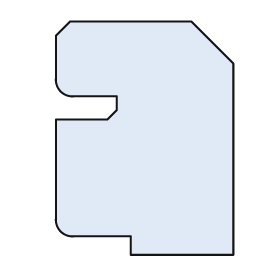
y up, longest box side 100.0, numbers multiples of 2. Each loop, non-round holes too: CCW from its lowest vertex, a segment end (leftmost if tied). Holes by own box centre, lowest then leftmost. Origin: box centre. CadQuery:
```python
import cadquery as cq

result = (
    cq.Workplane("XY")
    .moveTo(-6.0, -50.0)
    .lineTo(38.0, -50.0)
    .lineTo(38.0, 32.0)
    .lineTo(20.0, 50.0)
    .lineTo(-32.0, 50.0)
    .lineTo(-38.0, 44.0)
    .lineTo(-38.0, 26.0)
    .threePointArc((-36.0, 20.0), (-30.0, 18.0))
    .lineTo(-12.0, 18.0)
    .lineTo(-12.0, 12.0)
    .lineTo(-16.0, 8.0)
    .lineTo(-38.0, 8.0)
    .lineTo(-38.0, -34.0)
    .threePointArc((-36.0, -40.0), (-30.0, -42.0))
    .lineTo(-6.0, -42.0)
    .close()
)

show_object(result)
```